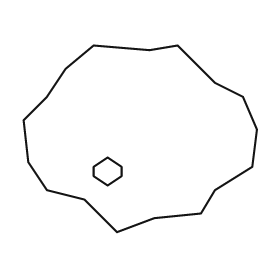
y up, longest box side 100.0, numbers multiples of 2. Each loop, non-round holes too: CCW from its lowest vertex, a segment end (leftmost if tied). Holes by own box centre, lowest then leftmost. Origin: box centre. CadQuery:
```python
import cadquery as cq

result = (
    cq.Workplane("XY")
    .moveTo(-10.0, -40.0)
    .lineTo(6.0, -34.0)
    .lineTo(26.0, -32.0)
    .lineTo(32.0, -22.0)
    .lineTo(48.0, -12.0)
    .lineTo(50.0, 4.0)
    .lineTo(44.0, 18.0)
    .lineTo(32.0, 24.0)
    .lineTo(16.0, 40.0)
    .lineTo(4.0, 38.0)
    .lineTo(-20.0, 40.0)
    .lineTo(-32.0, 30.0)
    .lineTo(-40.0, 18.0)
    .lineTo(-50.0, 8.0)
    .lineTo(-48.0, -10.0)
    .lineTo(-40.0, -22.0)
    .lineTo(-24.0, -26.0)
    .close()
    .moveTo(-14.0, -20.0)
    .lineTo(-8.0, -16.0)
    .lineTo(-8.0, -12.0)
    .lineTo(-14.0, -8.0)
    .lineTo(-20.0, -12.0)
    .lineTo(-20.0, -16.0)
    .close()
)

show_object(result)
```